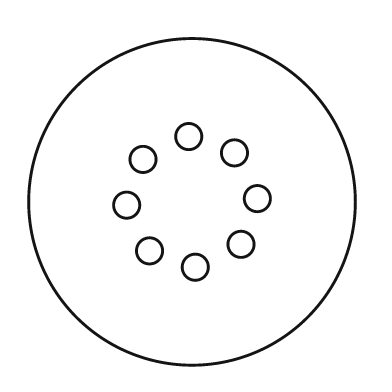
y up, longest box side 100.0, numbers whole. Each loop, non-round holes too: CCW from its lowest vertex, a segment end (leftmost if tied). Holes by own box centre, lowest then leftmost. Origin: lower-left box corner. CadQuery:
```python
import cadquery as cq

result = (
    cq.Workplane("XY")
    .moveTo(50.0, 50.0)
    .circle(50.0)
    .moveTo(51.0, 30.0)
    .circle(4.0)
    .moveTo(37.0, 35.0)
    .circle(4.0)
    .moveTo(65.0, 37.0)
    .circle(4.0)
    .moveTo(30.0, 49.0)
    .circle(4.0)
    .moveTo(70.0, 51.0)
    .circle(4.0)
    .moveTo(35.0, 63.0)
    .circle(4.0)
    .moveTo(63.0, 65.0)
    .circle(4.0)
    .moveTo(49.0, 70.0)
    .circle(4.0)
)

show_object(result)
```